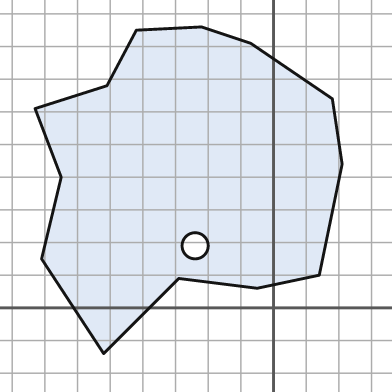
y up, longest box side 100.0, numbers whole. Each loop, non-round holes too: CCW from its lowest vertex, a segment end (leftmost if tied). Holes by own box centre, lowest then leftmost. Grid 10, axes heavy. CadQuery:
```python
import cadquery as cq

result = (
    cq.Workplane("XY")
    .moveTo(-52.0, -14.0)
    .lineTo(-29.0, 9.0)
    .lineTo(-5.0, 6.0)
    .lineTo(14.0, 10.0)
    .lineTo(21.0, 44.0)
    .lineTo(18.0, 64.0)
    .lineTo(-7.0, 81.0)
    .lineTo(-22.0, 86.0)
    .lineTo(-42.0, 85.0)
    .lineTo(-51.0, 68.0)
    .lineTo(-73.0, 61.0)
    .lineTo(-65.0, 40.0)
    .lineTo(-71.0, 15.0)
    .close()
    .moveTo(-24.0, 19.0)
    .circle(4.0)
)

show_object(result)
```